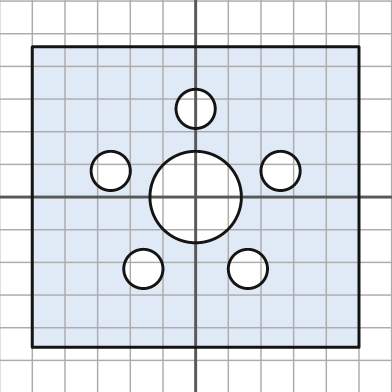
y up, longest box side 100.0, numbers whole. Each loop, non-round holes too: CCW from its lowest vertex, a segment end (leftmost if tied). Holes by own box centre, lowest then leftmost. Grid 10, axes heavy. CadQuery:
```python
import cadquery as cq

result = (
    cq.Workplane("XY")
    .moveTo(-50.0, -46.0)
    .lineTo(50.0, -46.0)
    .lineTo(50.0, 46.0)
    .lineTo(-50.0, 46.0)
    .close()
    .moveTo(-16.0, -22.0)
    .circle(6.0)
    .moveTo(16.0, -22.0)
    .circle(6.0)
    .moveTo(0.0, 0.0)
    .circle(14.0)
    .moveTo(-26.0, 8.0)
    .circle(6.0)
    .moveTo(26.0, 8.0)
    .circle(6.0)
    .moveTo(0.0, 27.0)
    .circle(6.0)
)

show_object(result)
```